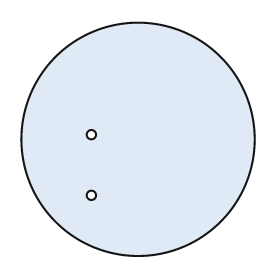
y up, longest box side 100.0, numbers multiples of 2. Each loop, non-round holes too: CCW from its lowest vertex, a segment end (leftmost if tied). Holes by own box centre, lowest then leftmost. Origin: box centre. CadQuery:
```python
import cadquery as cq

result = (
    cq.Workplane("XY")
    .moveTo(0.0, 0.0)
    .circle(50.0)
    .moveTo(-20.0, -24.0)
    .circle(2.0)
    .moveTo(-20.0, 2.0)
    .circle(2.0)
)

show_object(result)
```